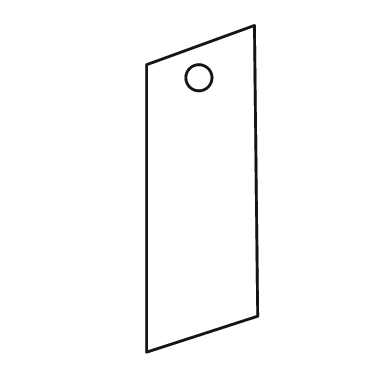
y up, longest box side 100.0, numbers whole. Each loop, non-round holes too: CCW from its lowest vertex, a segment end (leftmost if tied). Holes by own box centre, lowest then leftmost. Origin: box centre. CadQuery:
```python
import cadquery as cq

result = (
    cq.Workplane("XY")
    .moveTo(-17.0, -50.0)
    .lineTo(17.0, -39.0)
    .lineTo(16.0, 50.0)
    .lineTo(-17.0, 38.0)
    .close()
    .moveTo(-1.0, 34.0)
    .circle(4.0)
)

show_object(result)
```